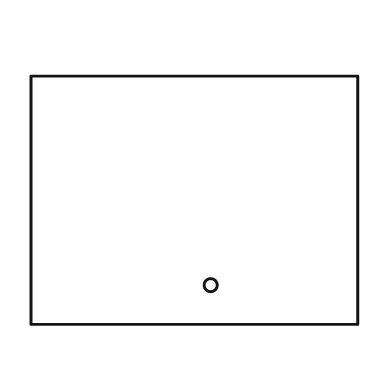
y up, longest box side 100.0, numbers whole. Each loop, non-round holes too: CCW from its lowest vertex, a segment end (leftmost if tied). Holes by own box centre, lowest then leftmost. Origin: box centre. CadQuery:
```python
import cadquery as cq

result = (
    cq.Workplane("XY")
    .moveTo(-50.0, -38.0)
    .lineTo(50.0, -38.0)
    .lineTo(50.0, 38.0)
    .lineTo(-50.0, 38.0)
    .close()
    .moveTo(5.0, -26.0)
    .circle(2.0)
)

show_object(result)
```